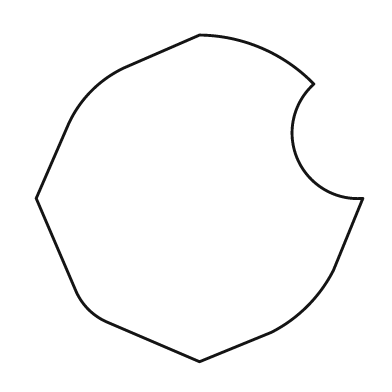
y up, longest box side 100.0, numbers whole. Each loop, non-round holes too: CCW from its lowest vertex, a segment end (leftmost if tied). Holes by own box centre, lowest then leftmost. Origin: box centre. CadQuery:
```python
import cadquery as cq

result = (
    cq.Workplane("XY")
    .moveTo(0.0, -50.0)
    .lineTo(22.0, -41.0)
    .threePointArc((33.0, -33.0), (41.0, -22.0))
    .lineTo(50.0, 0.0)
    .threePointArc((30.0, 12.0), (35.0, 35.0))
    .threePointArc((19.0, 46.0), (0.0, 50.0))
    .lineTo(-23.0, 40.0)
    .threePointArc((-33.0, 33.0), (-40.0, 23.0))
    .lineTo(-50.0, 0.0)
    .lineTo(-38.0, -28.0)
    .threePointArc((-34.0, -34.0), (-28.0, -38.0))
    .close()
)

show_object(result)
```